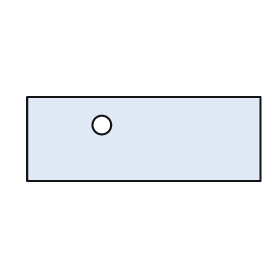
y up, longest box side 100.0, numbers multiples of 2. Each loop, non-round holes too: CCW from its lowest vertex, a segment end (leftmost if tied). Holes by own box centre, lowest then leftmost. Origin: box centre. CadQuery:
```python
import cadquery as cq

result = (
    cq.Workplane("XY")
    .moveTo(-50.0, -18.0)
    .lineTo(50.0, -18.0)
    .lineTo(50.0, 18.0)
    .lineTo(-50.0, 18.0)
    .close()
    .moveTo(-18.0, 6.0)
    .circle(4.0)
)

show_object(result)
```